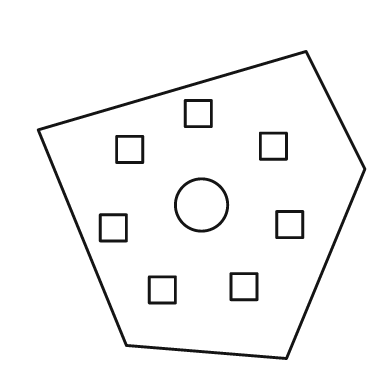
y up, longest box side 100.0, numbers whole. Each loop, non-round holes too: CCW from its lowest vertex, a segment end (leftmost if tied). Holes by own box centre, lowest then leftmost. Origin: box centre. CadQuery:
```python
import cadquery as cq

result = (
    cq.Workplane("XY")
    .moveTo(26.0, -47.0)
    .lineTo(50.0, 11.0)
    .lineTo(32.0, 47.0)
    .lineTo(-50.0, 23.0)
    .lineTo(-23.0, -43.0)
    .close()
    .moveTo(-16.0, -30.0)
    .lineTo(-8.0, -30.0)
    .lineTo(-8.0, -22.0)
    .lineTo(-16.0, -22.0)
    .close()
    .moveTo(9.0, -29.0)
    .lineTo(17.0, -29.0)
    .lineTo(17.0, -21.0)
    .lineTo(9.0, -21.0)
    .close()
    .moveTo(-31.0, -11.0)
    .lineTo(-23.0, -11.0)
    .lineTo(-23.0, -3.0)
    .lineTo(-31.0, -3.0)
    .close()
    .moveTo(23.0, -10.0)
    .lineTo(31.0, -10.0)
    .lineTo(31.0, -2.0)
    .lineTo(23.0, -2.0)
    .close()
    .moveTo(0.0, 0.0)
    .circle(8.0)
    .moveTo(-26.0, 13.0)
    .lineTo(-18.0, 13.0)
    .lineTo(-18.0, 21.0)
    .lineTo(-26.0, 21.0)
    .close()
    .moveTo(18.0, 14.0)
    .lineTo(26.0, 14.0)
    .lineTo(26.0, 22.0)
    .lineTo(18.0, 22.0)
    .close()
    .moveTo(-5.0, 24.0)
    .lineTo(3.0, 24.0)
    .lineTo(3.0, 32.0)
    .lineTo(-5.0, 32.0)
    .close()
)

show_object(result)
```